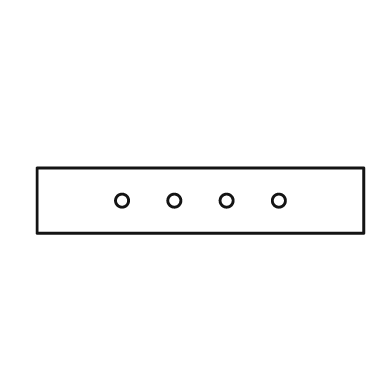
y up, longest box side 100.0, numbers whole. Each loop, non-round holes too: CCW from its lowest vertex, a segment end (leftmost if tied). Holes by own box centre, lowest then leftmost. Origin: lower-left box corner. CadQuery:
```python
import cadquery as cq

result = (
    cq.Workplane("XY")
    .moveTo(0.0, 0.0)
    .lineTo(100.0, 0.0)
    .lineTo(100.0, 20.0)
    .lineTo(0.0, 20.0)
    .close()
    .moveTo(26.0, 10.0)
    .circle(2.0)
    .moveTo(42.0, 10.0)
    .circle(2.0)
    .moveTo(58.0, 10.0)
    .circle(2.0)
    .moveTo(74.0, 10.0)
    .circle(2.0)
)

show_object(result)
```